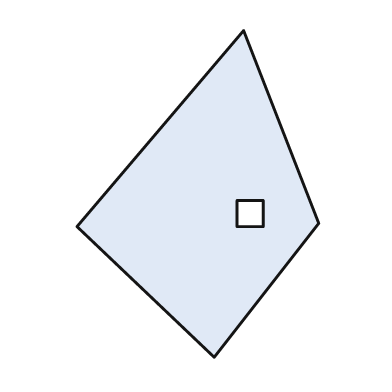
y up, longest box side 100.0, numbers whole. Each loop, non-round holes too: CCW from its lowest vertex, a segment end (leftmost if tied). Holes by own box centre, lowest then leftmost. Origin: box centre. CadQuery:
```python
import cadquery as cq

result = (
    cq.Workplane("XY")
    .moveTo(5.0, -50.0)
    .lineTo(37.0, -9.0)
    .lineTo(14.0, 50.0)
    .lineTo(-37.0, -10.0)
    .close()
    .moveTo(12.0, -10.0)
    .lineTo(20.0, -10.0)
    .lineTo(20.0, -2.0)
    .lineTo(12.0, -2.0)
    .close()
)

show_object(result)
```